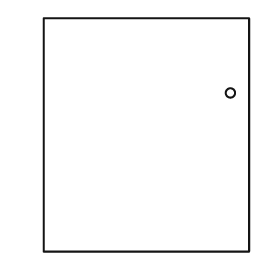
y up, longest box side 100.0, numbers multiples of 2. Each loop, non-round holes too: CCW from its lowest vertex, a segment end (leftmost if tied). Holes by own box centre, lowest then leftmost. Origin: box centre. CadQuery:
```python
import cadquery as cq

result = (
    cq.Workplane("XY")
    .moveTo(-44.0, -50.0)
    .lineTo(44.0, -50.0)
    .lineTo(44.0, 50.0)
    .lineTo(-44.0, 50.0)
    .close()
    .moveTo(36.0, 18.0)
    .circle(2.0)
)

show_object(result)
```